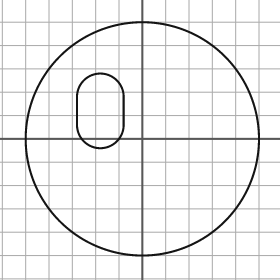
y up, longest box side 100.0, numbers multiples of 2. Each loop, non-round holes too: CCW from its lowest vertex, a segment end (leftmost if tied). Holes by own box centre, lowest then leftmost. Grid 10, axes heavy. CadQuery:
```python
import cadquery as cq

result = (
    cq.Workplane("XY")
    .moveTo(0.0, 0.0)
    .circle(50.0)
    .moveTo(-28.0, 6.0)
    .threePointArc((-18.0, -4.0), (-8.0, 6.0))
    .lineTo(-8.0, 18.0)
    .threePointArc((-18.0, 28.0), (-28.0, 18.0))
    .close()
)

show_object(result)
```